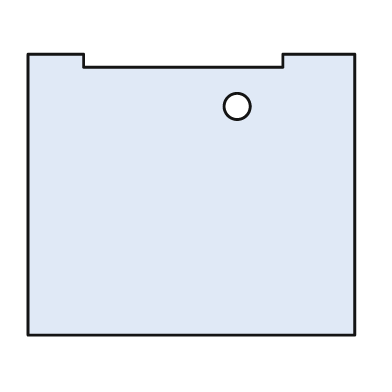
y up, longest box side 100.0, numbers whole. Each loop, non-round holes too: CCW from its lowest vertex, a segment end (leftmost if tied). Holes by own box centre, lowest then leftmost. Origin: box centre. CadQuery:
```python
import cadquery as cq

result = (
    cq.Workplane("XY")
    .moveTo(-50.0, -43.0)
    .lineTo(50.0, -43.0)
    .lineTo(50.0, 43.0)
    .lineTo(28.0, 43.0)
    .lineTo(28.0, 39.0)
    .lineTo(-33.0, 39.0)
    .lineTo(-33.0, 43.0)
    .lineTo(-50.0, 43.0)
    .close()
    .moveTo(14.0, 27.0)
    .circle(4.0)
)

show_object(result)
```